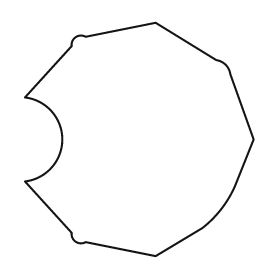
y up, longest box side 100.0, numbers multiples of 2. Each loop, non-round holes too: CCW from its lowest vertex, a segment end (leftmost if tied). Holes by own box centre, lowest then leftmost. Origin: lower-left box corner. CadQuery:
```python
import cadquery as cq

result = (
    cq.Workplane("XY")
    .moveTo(56.0, 0.0)
    .lineTo(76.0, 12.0)
    .threePointArc((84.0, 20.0), (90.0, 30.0))
    .lineTo(98.0, 50.0)
    .lineTo(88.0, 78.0)
    .threePointArc((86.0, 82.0), (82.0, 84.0))
    .lineTo(56.0, 100.0)
    .lineTo(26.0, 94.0)
    .threePointArc((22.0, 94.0), (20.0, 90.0))
    .lineTo(0.0, 68.0)
    .threePointArc((16.0, 50.0), (0.0, 32.0))
    .lineTo(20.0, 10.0)
    .threePointArc((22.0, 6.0), (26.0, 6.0))
    .close()
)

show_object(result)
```